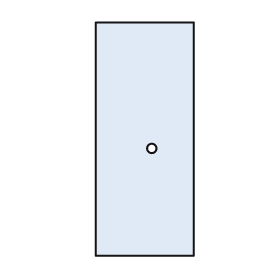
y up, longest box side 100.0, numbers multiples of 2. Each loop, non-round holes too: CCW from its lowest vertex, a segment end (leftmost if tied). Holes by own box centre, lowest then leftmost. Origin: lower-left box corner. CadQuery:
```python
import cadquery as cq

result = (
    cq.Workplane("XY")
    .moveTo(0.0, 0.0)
    .lineTo(42.0, 0.0)
    .lineTo(42.0, 100.0)
    .lineTo(0.0, 100.0)
    .close()
    .moveTo(24.0, 46.0)
    .circle(2.0)
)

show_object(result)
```